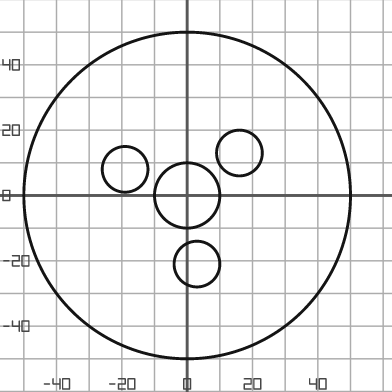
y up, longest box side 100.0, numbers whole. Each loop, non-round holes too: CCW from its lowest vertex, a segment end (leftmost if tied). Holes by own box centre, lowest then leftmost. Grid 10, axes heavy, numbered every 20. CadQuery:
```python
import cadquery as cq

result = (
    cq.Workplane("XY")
    .moveTo(0.0, 0.0)
    .circle(50.0)
    .moveTo(3.0, -21.0)
    .circle(7.0)
    .moveTo(0.0, 0.0)
    .circle(10.0)
    .moveTo(-19.0, 8.0)
    .circle(7.0)
    .moveTo(16.0, 13.0)
    .circle(7.0)
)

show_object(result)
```